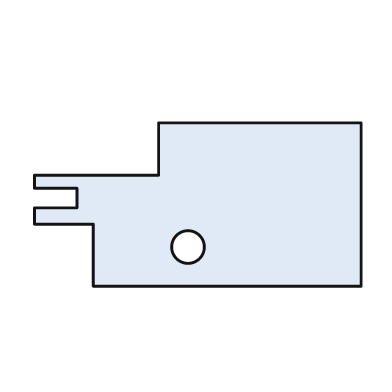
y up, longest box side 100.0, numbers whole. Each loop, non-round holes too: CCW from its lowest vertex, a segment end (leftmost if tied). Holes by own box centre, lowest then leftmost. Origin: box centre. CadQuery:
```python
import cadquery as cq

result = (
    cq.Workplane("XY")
    .moveTo(-32.0, -25.0)
    .lineTo(50.0, -25.0)
    .lineTo(50.0, 25.0)
    .lineTo(-12.0, 25.0)
    .lineTo(-12.0, 9.0)
    .lineTo(-50.0, 9.0)
    .lineTo(-50.0, 5.0)
    .lineTo(-37.0, 5.0)
    .lineTo(-37.0, -1.0)
    .lineTo(-50.0, -1.0)
    .lineTo(-50.0, -6.0)
    .lineTo(-32.0, -6.0)
    .close()
    .moveTo(-3.0, -13.0)
    .circle(5.0)
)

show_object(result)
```